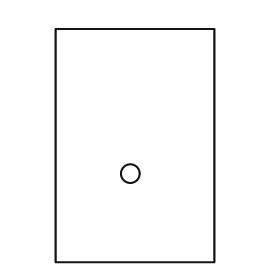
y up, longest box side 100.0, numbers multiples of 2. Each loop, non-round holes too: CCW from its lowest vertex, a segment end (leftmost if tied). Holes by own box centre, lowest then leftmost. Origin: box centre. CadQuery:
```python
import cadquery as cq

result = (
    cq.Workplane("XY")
    .moveTo(-34.0, -50.0)
    .lineTo(34.0, -50.0)
    .lineTo(34.0, 50.0)
    .lineTo(-34.0, 50.0)
    .close()
    .moveTo(-2.0, -12.0)
    .circle(4.0)
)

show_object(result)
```